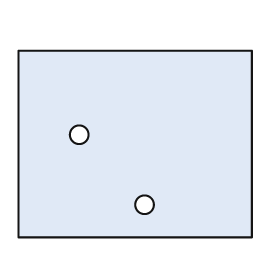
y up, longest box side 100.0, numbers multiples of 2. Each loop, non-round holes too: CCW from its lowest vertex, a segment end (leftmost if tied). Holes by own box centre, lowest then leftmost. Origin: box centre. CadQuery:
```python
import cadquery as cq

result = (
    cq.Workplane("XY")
    .moveTo(-50.0, -40.0)
    .lineTo(50.0, -40.0)
    .lineTo(50.0, 40.0)
    .lineTo(-50.0, 40.0)
    .close()
    .moveTo(4.0, -26.0)
    .circle(4.0)
    .moveTo(-24.0, 4.0)
    .circle(4.0)
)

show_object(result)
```